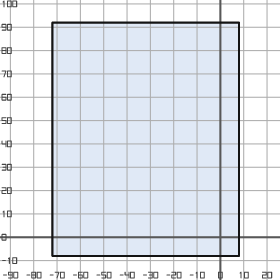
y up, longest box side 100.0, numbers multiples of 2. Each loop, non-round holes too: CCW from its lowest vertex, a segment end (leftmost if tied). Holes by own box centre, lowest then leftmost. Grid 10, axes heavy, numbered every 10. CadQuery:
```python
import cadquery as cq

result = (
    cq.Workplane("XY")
    .moveTo(-72.0, -8.0)
    .lineTo(8.0, -8.0)
    .lineTo(8.0, 92.0)
    .lineTo(-72.0, 92.0)
    .close()
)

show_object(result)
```